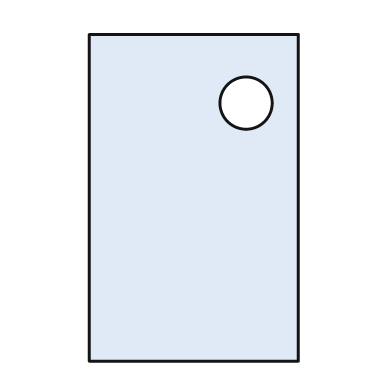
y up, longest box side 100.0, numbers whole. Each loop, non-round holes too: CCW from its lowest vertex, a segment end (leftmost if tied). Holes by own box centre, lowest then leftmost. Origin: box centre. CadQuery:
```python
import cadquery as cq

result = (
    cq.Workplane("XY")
    .moveTo(-32.0, -50.0)
    .lineTo(32.0, -50.0)
    .lineTo(32.0, 50.0)
    .lineTo(-32.0, 50.0)
    .close()
    .moveTo(16.0, 29.0)
    .circle(8.0)
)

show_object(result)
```